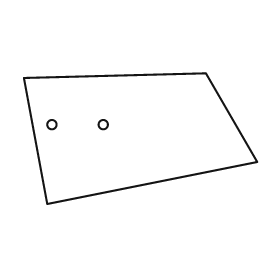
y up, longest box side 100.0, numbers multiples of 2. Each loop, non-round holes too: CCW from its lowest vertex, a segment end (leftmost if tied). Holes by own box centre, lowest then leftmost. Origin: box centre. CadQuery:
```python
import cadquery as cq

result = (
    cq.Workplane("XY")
    .moveTo(-40.0, -28.0)
    .lineTo(50.0, -10.0)
    .lineTo(28.0, 28.0)
    .lineTo(-50.0, 26.0)
    .close()
    .moveTo(-38.0, 6.0)
    .circle(2.0)
    .moveTo(-16.0, 6.0)
    .circle(2.0)
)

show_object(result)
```